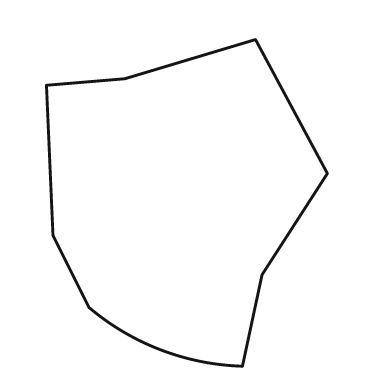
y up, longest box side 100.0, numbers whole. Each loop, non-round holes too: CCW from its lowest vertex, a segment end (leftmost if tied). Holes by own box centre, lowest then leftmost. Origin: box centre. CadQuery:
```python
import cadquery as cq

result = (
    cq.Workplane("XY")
    .moveTo(17.0, -50.0)
    .lineTo(23.0, -22.0)
    .lineTo(43.0, 9.0)
    .lineTo(21.0, 50.0)
    .lineTo(-19.0, 38.0)
    .lineTo(-43.0, 36.0)
    .lineTo(-41.0, -10.0)
    .lineTo(-30.0, -32.0)
    .threePointArc((-8.0, -45.0), (17.0, -50.0))
    .close()
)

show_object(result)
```